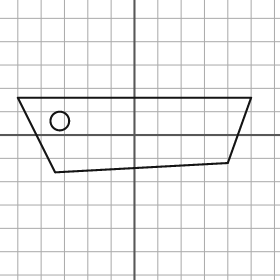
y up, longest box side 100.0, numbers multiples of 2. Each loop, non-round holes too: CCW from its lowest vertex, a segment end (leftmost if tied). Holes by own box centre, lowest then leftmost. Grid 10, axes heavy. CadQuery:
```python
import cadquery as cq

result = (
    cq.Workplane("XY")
    .moveTo(-34.0, -16.0)
    .lineTo(40.0, -12.0)
    .lineTo(50.0, 16.0)
    .lineTo(-50.0, 16.0)
    .close()
    .moveTo(-32.0, 6.0)
    .circle(4.0)
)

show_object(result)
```